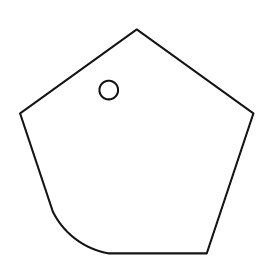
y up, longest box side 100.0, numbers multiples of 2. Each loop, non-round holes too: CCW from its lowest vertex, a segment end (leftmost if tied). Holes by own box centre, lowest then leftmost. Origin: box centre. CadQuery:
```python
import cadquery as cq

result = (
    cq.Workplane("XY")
    .moveTo(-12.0, -48.0)
    .lineTo(30.0, -48.0)
    .lineTo(50.0, 12.0)
    .lineTo(0.0, 48.0)
    .lineTo(-50.0, 12.0)
    .lineTo(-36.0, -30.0)
    .threePointArc((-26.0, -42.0), (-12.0, -48.0))
    .close()
    .moveTo(-12.0, 22.0)
    .circle(4.0)
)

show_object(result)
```